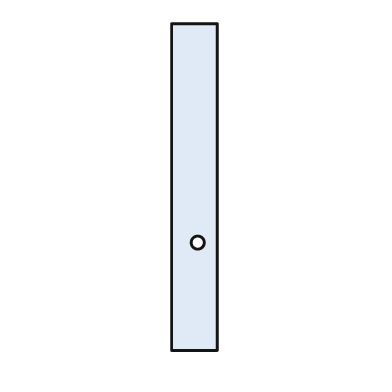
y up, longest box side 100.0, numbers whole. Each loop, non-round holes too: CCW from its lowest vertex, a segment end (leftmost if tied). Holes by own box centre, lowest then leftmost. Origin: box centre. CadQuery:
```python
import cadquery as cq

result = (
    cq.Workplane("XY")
    .moveTo(-7.0, -50.0)
    .lineTo(7.0, -50.0)
    .lineTo(7.0, 50.0)
    .lineTo(-7.0, 50.0)
    .close()
    .moveTo(1.0, -17.0)
    .circle(2.0)
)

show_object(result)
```